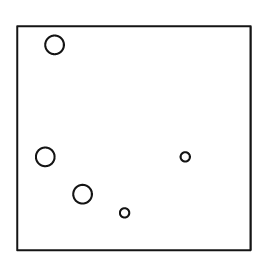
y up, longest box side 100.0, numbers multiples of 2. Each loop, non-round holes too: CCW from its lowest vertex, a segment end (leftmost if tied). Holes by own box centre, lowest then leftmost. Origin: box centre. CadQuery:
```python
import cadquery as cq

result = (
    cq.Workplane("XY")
    .moveTo(-50.0, -48.0)
    .lineTo(50.0, -48.0)
    .lineTo(50.0, 48.0)
    .lineTo(-50.0, 48.0)
    .close()
    .moveTo(-4.0, -32.0)
    .circle(2.0)
    .moveTo(-22.0, -24.0)
    .circle(4.0)
    .moveTo(-38.0, -8.0)
    .circle(4.0)
    .moveTo(22.0, -8.0)
    .circle(2.0)
    .moveTo(-34.0, 40.0)
    .circle(4.0)
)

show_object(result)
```